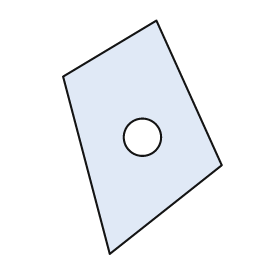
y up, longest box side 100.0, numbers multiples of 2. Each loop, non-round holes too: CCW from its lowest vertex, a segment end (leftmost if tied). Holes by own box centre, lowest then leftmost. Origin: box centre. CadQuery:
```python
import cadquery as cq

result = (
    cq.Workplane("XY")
    .moveTo(-14.0, -50.0)
    .lineTo(34.0, -12.0)
    .lineTo(6.0, 50.0)
    .lineTo(-34.0, 26.0)
    .close()
    .moveTo(0.0, 0.0)
    .circle(8.0)
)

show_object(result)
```